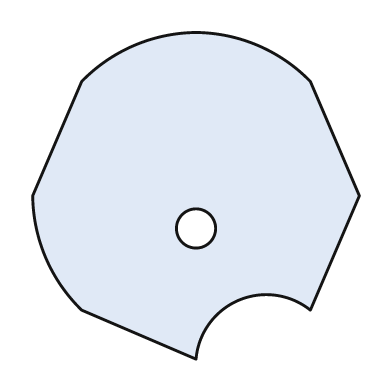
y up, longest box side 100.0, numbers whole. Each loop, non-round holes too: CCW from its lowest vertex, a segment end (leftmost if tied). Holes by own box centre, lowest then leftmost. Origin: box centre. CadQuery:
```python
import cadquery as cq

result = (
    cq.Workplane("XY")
    .moveTo(0.0, -50.0)
    .threePointArc((13.0, -32.0), (35.0, -35.0))
    .lineTo(50.0, 0.0)
    .lineTo(35.0, 35.0)
    .threePointArc((19.0, 46.0), (0.0, 50.0))
    .threePointArc((-19.0, 46.0), (-35.0, 35.0))
    .lineTo(-50.0, 0.0)
    .threePointArc((-46.0, -19.0), (-35.0, -35.0))
    .close()
    .moveTo(0.0, -10.0)
    .circle(6.0)
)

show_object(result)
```